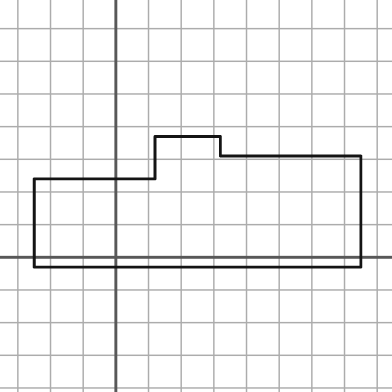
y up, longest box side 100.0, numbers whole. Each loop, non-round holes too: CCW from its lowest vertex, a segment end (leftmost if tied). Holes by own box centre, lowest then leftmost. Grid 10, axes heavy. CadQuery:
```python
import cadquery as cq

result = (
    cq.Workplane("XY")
    .moveTo(-25.0, -3.0)
    .lineTo(75.0, -3.0)
    .lineTo(75.0, 31.0)
    .lineTo(32.0, 31.0)
    .lineTo(32.0, 37.0)
    .lineTo(12.0, 37.0)
    .lineTo(12.0, 24.0)
    .lineTo(-25.0, 24.0)
    .close()
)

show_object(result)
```